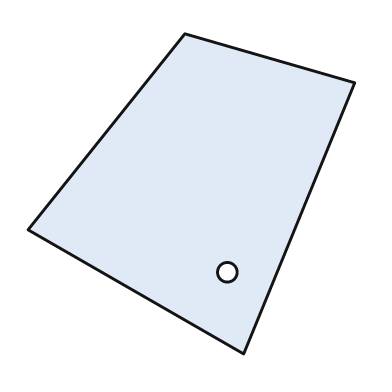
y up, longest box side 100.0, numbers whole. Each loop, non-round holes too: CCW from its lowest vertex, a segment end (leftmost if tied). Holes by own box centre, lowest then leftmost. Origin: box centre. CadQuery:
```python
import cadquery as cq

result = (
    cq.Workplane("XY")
    .moveTo(16.0, -49.0)
    .lineTo(50.0, 34.0)
    .lineTo(-2.0, 49.0)
    .lineTo(-50.0, -11.0)
    .close()
    .moveTo(11.0, -24.0)
    .circle(3.0)
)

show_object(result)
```